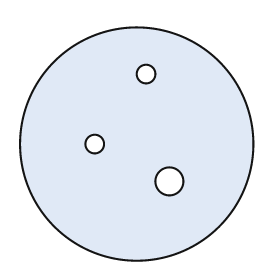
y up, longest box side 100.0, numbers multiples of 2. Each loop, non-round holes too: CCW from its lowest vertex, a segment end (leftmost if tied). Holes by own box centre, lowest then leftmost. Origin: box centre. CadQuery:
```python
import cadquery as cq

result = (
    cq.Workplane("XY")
    .moveTo(0.0, 0.0)
    .circle(50.0)
    .moveTo(14.0, -16.0)
    .circle(6.0)
    .moveTo(-18.0, 0.0)
    .circle(4.0)
    .moveTo(4.0, 30.0)
    .circle(4.0)
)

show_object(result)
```